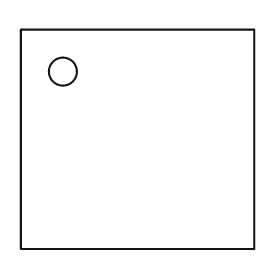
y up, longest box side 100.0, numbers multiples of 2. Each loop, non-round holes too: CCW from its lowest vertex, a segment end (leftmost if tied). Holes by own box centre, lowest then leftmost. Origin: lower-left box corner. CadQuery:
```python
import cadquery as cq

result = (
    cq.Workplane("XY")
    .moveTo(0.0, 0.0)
    .lineTo(100.0, 0.0)
    .lineTo(100.0, 94.0)
    .lineTo(0.0, 94.0)
    .close()
    .moveTo(18.0, 76.0)
    .circle(6.0)
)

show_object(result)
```